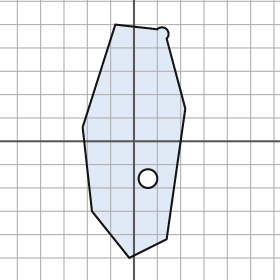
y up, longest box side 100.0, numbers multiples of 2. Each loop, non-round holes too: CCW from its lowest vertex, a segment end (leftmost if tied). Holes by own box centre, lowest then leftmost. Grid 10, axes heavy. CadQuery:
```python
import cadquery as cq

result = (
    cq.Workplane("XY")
    .moveTo(-2.0, -50.0)
    .lineTo(14.0, -42.0)
    .lineTo(22.0, 14.0)
    .lineTo(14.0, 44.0)
    .threePointArc((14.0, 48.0), (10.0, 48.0))
    .lineTo(-8.0, 50.0)
    .lineTo(-22.0, 6.0)
    .lineTo(-18.0, -30.0)
    .close()
    .moveTo(6.0, -16.0)
    .circle(4.0)
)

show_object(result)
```